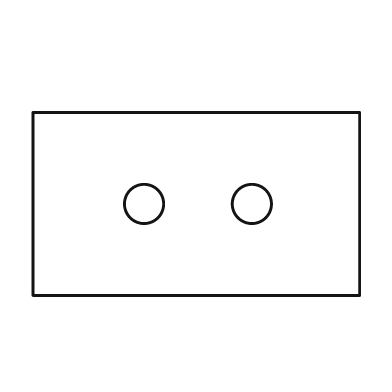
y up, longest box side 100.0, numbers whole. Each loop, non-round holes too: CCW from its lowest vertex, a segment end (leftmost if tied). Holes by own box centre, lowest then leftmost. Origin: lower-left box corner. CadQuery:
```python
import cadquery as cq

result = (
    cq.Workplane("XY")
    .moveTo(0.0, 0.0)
    .lineTo(100.0, 0.0)
    .lineTo(100.0, 56.0)
    .lineTo(0.0, 56.0)
    .close()
    .moveTo(34.0, 28.0)
    .circle(6.0)
    .moveTo(67.0, 28.0)
    .circle(6.0)
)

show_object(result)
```